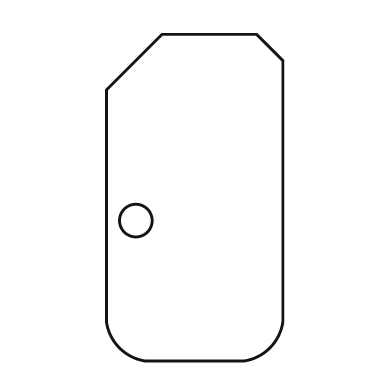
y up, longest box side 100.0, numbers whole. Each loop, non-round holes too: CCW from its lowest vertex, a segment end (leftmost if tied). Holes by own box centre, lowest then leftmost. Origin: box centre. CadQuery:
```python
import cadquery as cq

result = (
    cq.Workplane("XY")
    .moveTo(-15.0, -50.0)
    .lineTo(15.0, -50.0)
    .threePointArc((23.0, -46.0), (27.0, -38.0))
    .lineTo(27.0, 42.0)
    .lineTo(19.0, 50.0)
    .lineTo(-10.0, 50.0)
    .lineTo(-27.0, 33.0)
    .lineTo(-27.0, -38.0)
    .threePointArc((-23.0, -46.0), (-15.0, -50.0))
    .close()
    .moveTo(-18.0, -7.0)
    .circle(5.0)
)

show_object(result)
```